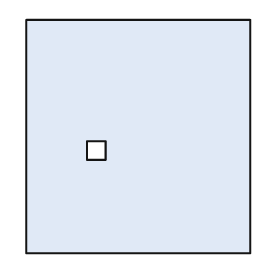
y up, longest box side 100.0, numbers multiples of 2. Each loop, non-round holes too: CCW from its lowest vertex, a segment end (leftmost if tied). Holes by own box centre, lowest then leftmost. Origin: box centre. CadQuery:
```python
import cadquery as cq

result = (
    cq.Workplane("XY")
    .moveTo(-48.0, -50.0)
    .lineTo(48.0, -50.0)
    .lineTo(48.0, 50.0)
    .lineTo(-48.0, 50.0)
    .close()
    .moveTo(-22.0, -10.0)
    .lineTo(-14.0, -10.0)
    .lineTo(-14.0, -2.0)
    .lineTo(-22.0, -2.0)
    .close()
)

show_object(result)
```